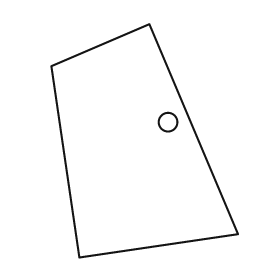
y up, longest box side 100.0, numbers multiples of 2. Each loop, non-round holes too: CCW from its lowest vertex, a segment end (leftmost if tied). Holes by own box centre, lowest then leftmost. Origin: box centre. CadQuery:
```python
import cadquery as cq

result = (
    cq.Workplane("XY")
    .moveTo(-28.0, -50.0)
    .lineTo(40.0, -40.0)
    .lineTo(2.0, 50.0)
    .lineTo(-40.0, 32.0)
    .close()
    .moveTo(10.0, 8.0)
    .circle(4.0)
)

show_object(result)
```